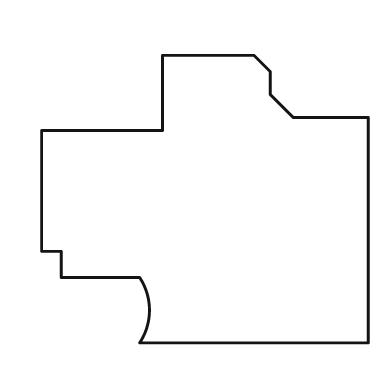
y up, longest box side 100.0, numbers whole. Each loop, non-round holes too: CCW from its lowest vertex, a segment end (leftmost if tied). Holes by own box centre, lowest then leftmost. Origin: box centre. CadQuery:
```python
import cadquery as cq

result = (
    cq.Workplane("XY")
    .moveTo(-20.0, -44.0)
    .lineTo(50.0, -44.0)
    .lineTo(50.0, 25.0)
    .lineTo(27.0, 25.0)
    .lineTo(20.0, 32.0)
    .lineTo(20.0, 39.0)
    .lineTo(15.0, 44.0)
    .lineTo(-13.0, 44.0)
    .lineTo(-13.0, 21.0)
    .lineTo(-50.0, 21.0)
    .lineTo(-50.0, -16.0)
    .lineTo(-44.0, -16.0)
    .lineTo(-44.0, -24.0)
    .lineTo(-20.0, -24.0)
    .threePointArc((-17.0, -34.0), (-20.0, -44.0))
    .close()
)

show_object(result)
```